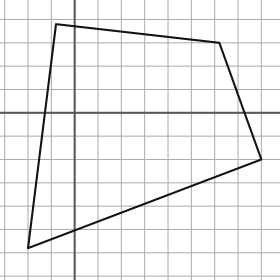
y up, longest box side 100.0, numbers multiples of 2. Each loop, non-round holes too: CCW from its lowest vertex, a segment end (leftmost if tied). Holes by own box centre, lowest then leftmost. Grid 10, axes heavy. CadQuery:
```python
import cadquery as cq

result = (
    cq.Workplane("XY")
    .moveTo(-20.0, -58.0)
    .lineTo(80.0, -20.0)
    .lineTo(62.0, 30.0)
    .lineTo(-8.0, 38.0)
    .close()
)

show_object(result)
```